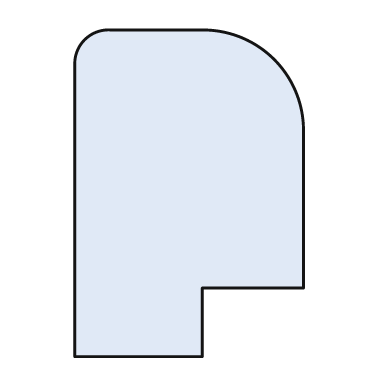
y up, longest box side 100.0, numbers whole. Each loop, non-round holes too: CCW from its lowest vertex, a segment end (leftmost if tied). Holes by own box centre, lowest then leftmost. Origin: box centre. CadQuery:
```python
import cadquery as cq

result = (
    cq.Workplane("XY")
    .moveTo(-35.0, -50.0)
    .lineTo(4.0, -50.0)
    .lineTo(4.0, -29.0)
    .lineTo(35.0, -29.0)
    .lineTo(35.0, 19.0)
    .threePointArc((26.0, 41.0), (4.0, 50.0))
    .lineTo(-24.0, 50.0)
    .threePointArc((-32.0, 47.0), (-35.0, 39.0))
    .close()
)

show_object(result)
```